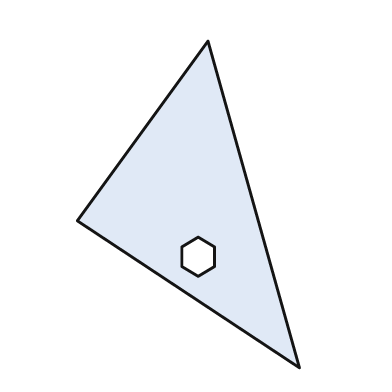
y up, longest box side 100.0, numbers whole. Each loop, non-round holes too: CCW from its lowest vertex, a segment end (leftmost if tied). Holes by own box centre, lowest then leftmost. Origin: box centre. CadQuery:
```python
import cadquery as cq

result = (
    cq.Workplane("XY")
    .moveTo(34.0, -50.0)
    .lineTo(6.0, 50.0)
    .lineTo(-34.0, -5.0)
    .close()
    .moveTo(3.0, -22.0)
    .lineTo(8.0, -19.0)
    .lineTo(8.0, -13.0)
    .lineTo(3.0, -10.0)
    .lineTo(-2.0, -13.0)
    .lineTo(-2.0, -19.0)
    .close()
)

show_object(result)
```